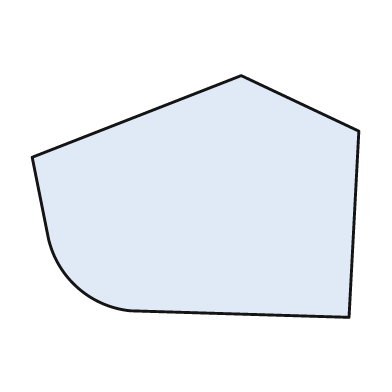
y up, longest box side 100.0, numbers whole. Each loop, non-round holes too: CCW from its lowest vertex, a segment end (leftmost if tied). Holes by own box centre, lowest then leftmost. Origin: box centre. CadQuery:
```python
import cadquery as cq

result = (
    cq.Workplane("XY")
    .moveTo(47.0, -37.0)
    .lineTo(50.0, 20.0)
    .lineTo(14.0, 37.0)
    .lineTo(-50.0, 12.0)
    .lineTo(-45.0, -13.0)
    .threePointArc((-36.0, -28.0), (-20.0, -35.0))
    .close()
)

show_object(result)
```